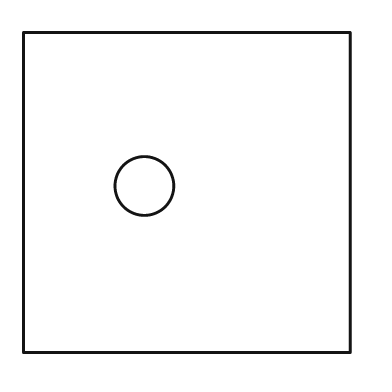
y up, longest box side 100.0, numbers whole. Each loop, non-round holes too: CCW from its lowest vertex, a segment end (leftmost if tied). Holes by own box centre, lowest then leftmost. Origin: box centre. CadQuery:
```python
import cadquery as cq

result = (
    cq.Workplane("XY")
    .moveTo(-50.0, -49.0)
    .lineTo(50.0, -49.0)
    .lineTo(50.0, 49.0)
    .lineTo(-50.0, 49.0)
    .close()
    .moveTo(-13.0, 2.0)
    .circle(9.0)
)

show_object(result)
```